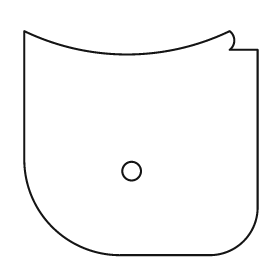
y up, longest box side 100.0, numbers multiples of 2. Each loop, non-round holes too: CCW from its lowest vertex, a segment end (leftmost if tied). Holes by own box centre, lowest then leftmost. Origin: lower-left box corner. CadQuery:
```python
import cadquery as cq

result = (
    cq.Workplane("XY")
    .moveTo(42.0, 0.0)
    .lineTo(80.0, 0.0)
    .threePointArc((94.0, 6.0), (100.0, 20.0))
    .lineTo(100.0, 88.0)
    .lineTo(88.0, 88.0)
    .threePointArc((90.0, 92.0), (88.0, 96.0))
    .threePointArc((44.0, 86.0), (0.0, 96.0))
    .lineTo(0.0, 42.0)
    .threePointArc((12.0, 12.0), (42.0, 0.0))
    .close()
    .moveTo(46.0, 36.0)
    .circle(4.0)
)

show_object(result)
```